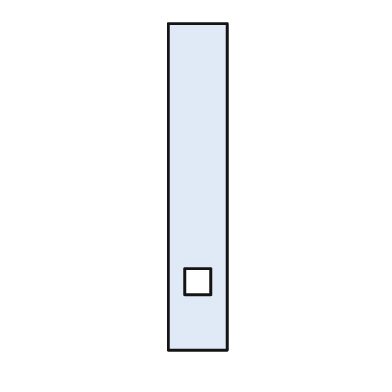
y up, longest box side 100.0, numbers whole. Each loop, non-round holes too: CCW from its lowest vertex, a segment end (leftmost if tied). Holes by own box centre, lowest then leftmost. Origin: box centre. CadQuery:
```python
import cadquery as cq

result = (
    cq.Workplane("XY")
    .moveTo(-9.0, -50.0)
    .lineTo(9.0, -50.0)
    .lineTo(9.0, 50.0)
    .lineTo(-9.0, 50.0)
    .close()
    .moveTo(-4.0, -33.0)
    .lineTo(4.0, -33.0)
    .lineTo(4.0, -25.0)
    .lineTo(-4.0, -25.0)
    .close()
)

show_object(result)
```